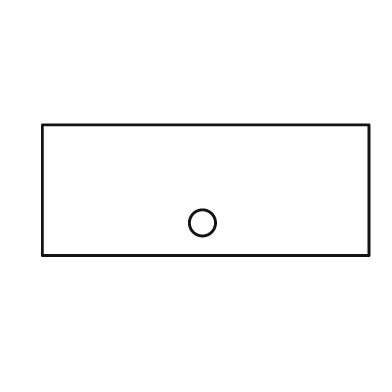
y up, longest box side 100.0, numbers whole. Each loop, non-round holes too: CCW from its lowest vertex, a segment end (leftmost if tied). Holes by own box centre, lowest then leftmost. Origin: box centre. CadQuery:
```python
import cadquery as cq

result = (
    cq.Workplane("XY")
    .moveTo(-50.0, -20.0)
    .lineTo(50.0, -20.0)
    .lineTo(50.0, 20.0)
    .lineTo(-50.0, 20.0)
    .close()
    .moveTo(-1.0, -10.0)
    .circle(4.0)
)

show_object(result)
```